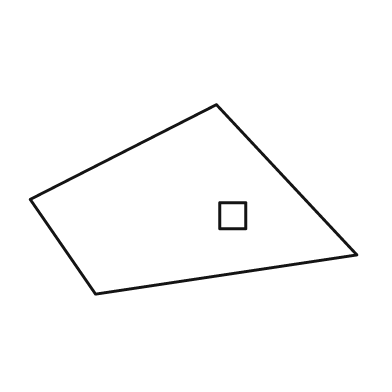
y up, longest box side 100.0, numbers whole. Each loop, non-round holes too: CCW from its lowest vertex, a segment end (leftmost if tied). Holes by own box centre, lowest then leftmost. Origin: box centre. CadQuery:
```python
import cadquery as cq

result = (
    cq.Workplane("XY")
    .moveTo(-30.0, -29.0)
    .lineTo(50.0, -17.0)
    .lineTo(7.0, 29.0)
    .lineTo(-50.0, 0.0)
    .close()
    .moveTo(8.0, -9.0)
    .lineTo(16.0, -9.0)
    .lineTo(16.0, -1.0)
    .lineTo(8.0, -1.0)
    .close()
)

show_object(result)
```